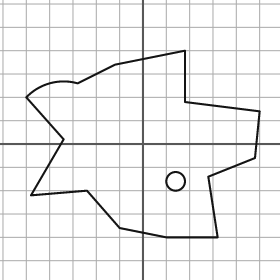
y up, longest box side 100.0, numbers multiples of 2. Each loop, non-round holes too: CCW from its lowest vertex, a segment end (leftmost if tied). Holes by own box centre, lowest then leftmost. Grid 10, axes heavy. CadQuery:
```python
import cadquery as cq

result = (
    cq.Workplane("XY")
    .moveTo(10.0, -40.0)
    .lineTo(32.0, -40.0)
    .lineTo(28.0, -14.0)
    .lineTo(48.0, -6.0)
    .lineTo(50.0, 14.0)
    .lineTo(18.0, 18.0)
    .lineTo(18.0, 40.0)
    .lineTo(-12.0, 34.0)
    .lineTo(-28.0, 26.0)
    .threePointArc((-40.0, 26.0), (-50.0, 20.0))
    .lineTo(-34.0, 2.0)
    .lineTo(-48.0, -22.0)
    .lineTo(-24.0, -20.0)
    .lineTo(-10.0, -36.0)
    .close()
    .moveTo(14.0, -16.0)
    .circle(4.0)
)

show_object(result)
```